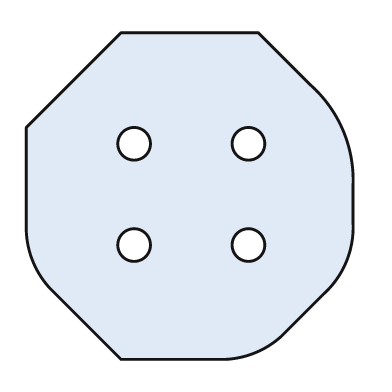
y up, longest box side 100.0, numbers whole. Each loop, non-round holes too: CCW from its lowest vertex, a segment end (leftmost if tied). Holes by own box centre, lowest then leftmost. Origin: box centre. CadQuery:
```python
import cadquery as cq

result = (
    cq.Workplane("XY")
    .moveTo(-21.0, -50.0)
    .lineTo(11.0, -50.0)
    .threePointArc((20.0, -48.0), (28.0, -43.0))
    .lineTo(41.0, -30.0)
    .threePointArc((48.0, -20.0), (50.0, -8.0))
    .lineTo(50.0, 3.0)
    .threePointArc((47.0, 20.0), (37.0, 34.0))
    .lineTo(21.0, 50.0)
    .lineTo(-21.0, 50.0)
    .lineTo(-50.0, 21.0)
    .lineTo(-50.0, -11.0)
    .threePointArc((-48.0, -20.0), (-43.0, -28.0))
    .close()
    .moveTo(-17.0, -15.0)
    .circle(5.0)
    .moveTo(18.0, -15.0)
    .circle(5.0)
    .moveTo(-17.0, 16.0)
    .circle(5.0)
    .moveTo(18.0, 16.0)
    .circle(5.0)
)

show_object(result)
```